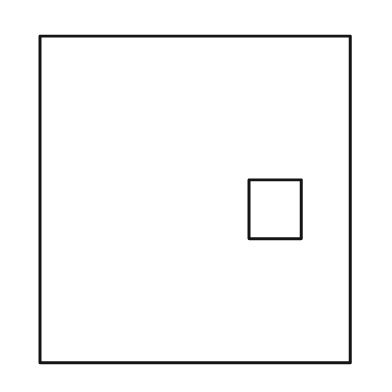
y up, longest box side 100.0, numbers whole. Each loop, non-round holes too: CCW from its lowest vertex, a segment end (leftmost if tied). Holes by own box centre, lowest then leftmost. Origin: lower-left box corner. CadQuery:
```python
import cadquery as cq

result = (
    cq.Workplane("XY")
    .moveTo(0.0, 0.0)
    .lineTo(95.0, 0.0)
    .lineTo(95.0, 100.0)
    .lineTo(0.0, 100.0)
    .close()
    .moveTo(64.0, 38.0)
    .lineTo(80.0, 38.0)
    .lineTo(80.0, 56.0)
    .lineTo(64.0, 56.0)
    .close()
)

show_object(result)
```